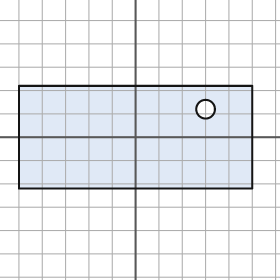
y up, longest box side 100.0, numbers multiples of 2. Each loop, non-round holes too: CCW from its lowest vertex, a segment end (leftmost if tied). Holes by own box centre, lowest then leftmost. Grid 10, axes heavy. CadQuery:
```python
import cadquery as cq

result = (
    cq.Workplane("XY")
    .moveTo(-50.0, -22.0)
    .lineTo(50.0, -22.0)
    .lineTo(50.0, 22.0)
    .lineTo(-50.0, 22.0)
    .close()
    .moveTo(30.0, 12.0)
    .circle(4.0)
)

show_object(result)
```